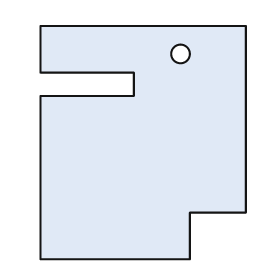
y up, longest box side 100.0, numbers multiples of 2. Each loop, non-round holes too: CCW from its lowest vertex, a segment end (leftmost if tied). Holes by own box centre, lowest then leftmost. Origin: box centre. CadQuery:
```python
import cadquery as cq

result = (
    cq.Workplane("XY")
    .moveTo(-44.0, -50.0)
    .lineTo(20.0, -50.0)
    .lineTo(20.0, -30.0)
    .lineTo(44.0, -30.0)
    .lineTo(44.0, 50.0)
    .lineTo(-44.0, 50.0)
    .lineTo(-44.0, 30.0)
    .lineTo(-4.0, 30.0)
    .lineTo(-4.0, 20.0)
    .lineTo(-44.0, 20.0)
    .close()
    .moveTo(16.0, 38.0)
    .circle(4.0)
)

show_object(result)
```